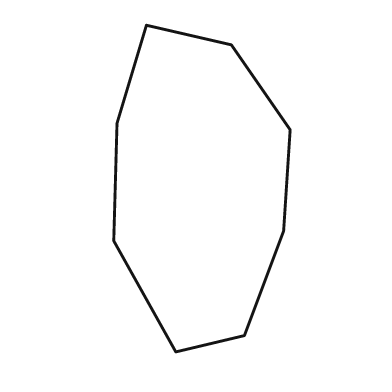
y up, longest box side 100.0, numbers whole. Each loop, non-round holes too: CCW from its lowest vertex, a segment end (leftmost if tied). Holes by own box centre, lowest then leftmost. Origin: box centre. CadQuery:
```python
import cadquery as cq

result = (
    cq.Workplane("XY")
    .moveTo(-8.0, -50.0)
    .lineTo(13.0, -45.0)
    .lineTo(25.0, -13.0)
    .lineTo(27.0, 18.0)
    .lineTo(9.0, 44.0)
    .lineTo(-17.0, 50.0)
    .lineTo(-26.0, 20.0)
    .lineTo(-27.0, -16.0)
    .close()
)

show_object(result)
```